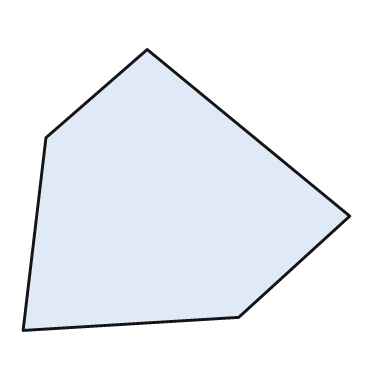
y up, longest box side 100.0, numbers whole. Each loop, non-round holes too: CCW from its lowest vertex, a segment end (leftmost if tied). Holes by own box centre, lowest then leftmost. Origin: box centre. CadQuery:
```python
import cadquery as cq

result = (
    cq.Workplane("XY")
    .moveTo(-50.0, -43.0)
    .lineTo(16.0, -39.0)
    .lineTo(50.0, -8.0)
    .lineTo(-12.0, 43.0)
    .lineTo(-43.0, 16.0)
    .close()
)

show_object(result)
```